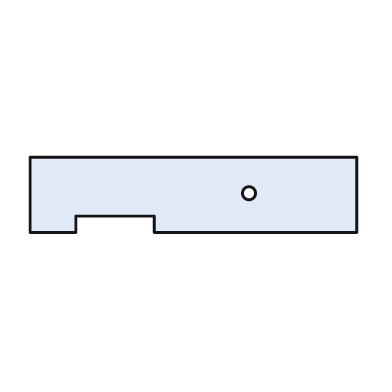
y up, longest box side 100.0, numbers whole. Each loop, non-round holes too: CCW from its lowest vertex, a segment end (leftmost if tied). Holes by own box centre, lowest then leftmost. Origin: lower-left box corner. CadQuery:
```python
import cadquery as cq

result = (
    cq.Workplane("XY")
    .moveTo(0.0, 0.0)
    .lineTo(14.0, 0.0)
    .lineTo(14.0, 5.0)
    .lineTo(38.0, 5.0)
    .lineTo(38.0, 0.0)
    .lineTo(100.0, 0.0)
    .lineTo(100.0, 23.0)
    .lineTo(0.0, 23.0)
    .close()
    .moveTo(67.0, 12.0)
    .circle(2.0)
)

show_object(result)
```